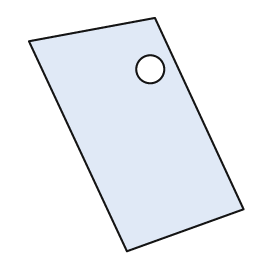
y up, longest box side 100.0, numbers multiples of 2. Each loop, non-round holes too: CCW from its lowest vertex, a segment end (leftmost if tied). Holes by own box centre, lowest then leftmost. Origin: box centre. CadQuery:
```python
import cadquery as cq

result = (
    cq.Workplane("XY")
    .moveTo(-4.0, -50.0)
    .lineTo(46.0, -32.0)
    .lineTo(8.0, 50.0)
    .lineTo(-46.0, 40.0)
    .close()
    .moveTo(6.0, 28.0)
    .circle(6.0)
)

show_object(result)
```